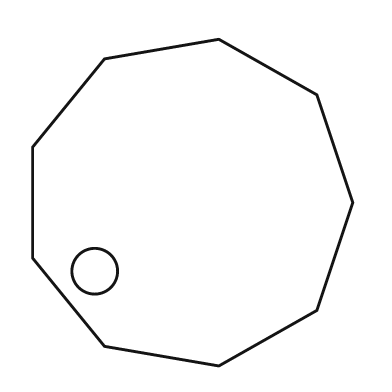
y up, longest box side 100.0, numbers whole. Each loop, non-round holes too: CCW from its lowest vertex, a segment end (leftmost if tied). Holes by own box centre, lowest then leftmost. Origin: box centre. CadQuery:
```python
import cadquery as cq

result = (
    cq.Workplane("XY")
    .moveTo(8.0, -50.0)
    .lineTo(38.0, -33.0)
    .lineTo(49.0, 0.0)
    .lineTo(38.0, 33.0)
    .lineTo(8.0, 50.0)
    .lineTo(-27.0, 44.0)
    .lineTo(-49.0, 17.0)
    .lineTo(-49.0, -17.0)
    .lineTo(-27.0, -44.0)
    .close()
    .moveTo(-30.0, -21.0)
    .circle(7.0)
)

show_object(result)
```